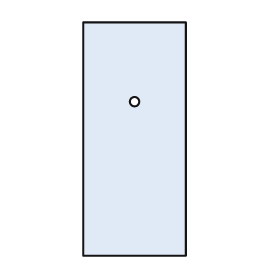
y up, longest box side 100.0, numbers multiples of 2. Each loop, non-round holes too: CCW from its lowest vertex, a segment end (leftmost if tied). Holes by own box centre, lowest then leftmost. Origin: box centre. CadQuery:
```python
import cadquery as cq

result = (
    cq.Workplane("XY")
    .moveTo(-22.0, -50.0)
    .lineTo(22.0, -50.0)
    .lineTo(22.0, 50.0)
    .lineTo(-22.0, 50.0)
    .close()
    .moveTo(0.0, 16.0)
    .circle(2.0)
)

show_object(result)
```